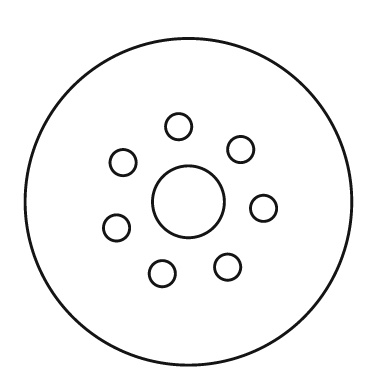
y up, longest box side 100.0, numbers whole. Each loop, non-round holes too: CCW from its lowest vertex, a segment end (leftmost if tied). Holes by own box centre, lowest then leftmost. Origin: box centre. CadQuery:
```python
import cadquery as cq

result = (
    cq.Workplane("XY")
    .moveTo(0.0, 0.0)
    .circle(50.0)
    .moveTo(-8.0, -22.0)
    .circle(4.0)
    .moveTo(12.0, -20.0)
    .circle(4.0)
    .moveTo(-22.0, -8.0)
    .circle(4.0)
    .moveTo(23.0, -2.0)
    .circle(4.0)
    .moveTo(0.0, 0.0)
    .circle(11.0)
    .moveTo(-20.0, 12.0)
    .circle(4.0)
    .moveTo(16.0, 16.0)
    .circle(4.0)
    .moveTo(-3.0, 23.0)
    .circle(4.0)
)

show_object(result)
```